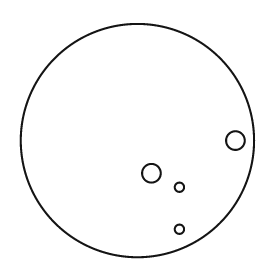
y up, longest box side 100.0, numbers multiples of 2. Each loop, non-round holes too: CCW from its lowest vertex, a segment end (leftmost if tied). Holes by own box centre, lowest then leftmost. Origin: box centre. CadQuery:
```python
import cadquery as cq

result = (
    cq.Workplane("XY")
    .moveTo(0.0, 0.0)
    .circle(50.0)
    .moveTo(18.0, -38.0)
    .circle(2.0)
    .moveTo(18.0, -20.0)
    .circle(2.0)
    .moveTo(6.0, -14.0)
    .circle(4.0)
    .moveTo(42.0, 0.0)
    .circle(4.0)
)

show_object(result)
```